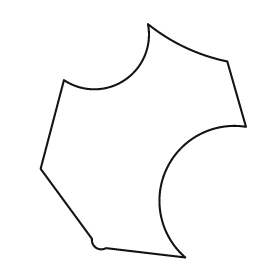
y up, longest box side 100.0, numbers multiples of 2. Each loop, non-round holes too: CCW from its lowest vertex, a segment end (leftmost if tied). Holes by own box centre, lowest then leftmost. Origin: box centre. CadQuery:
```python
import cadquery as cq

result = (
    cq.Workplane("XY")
    .moveTo(18.0, -50.0)
    .threePointArc((10.0, -12.0), (44.0, 6.0))
    .lineTo(36.0, 34.0)
    .threePointArc((18.0, 40.0), (2.0, 50.0))
    .threePointArc((-8.0, 26.0), (-34.0, 26.0))
    .lineTo(-44.0, -12.0)
    .lineTo(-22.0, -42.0)
    .threePointArc((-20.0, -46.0), (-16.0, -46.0))
    .close()
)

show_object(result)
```